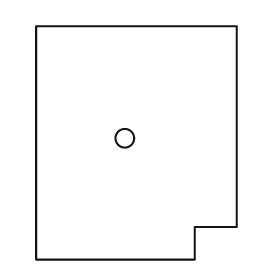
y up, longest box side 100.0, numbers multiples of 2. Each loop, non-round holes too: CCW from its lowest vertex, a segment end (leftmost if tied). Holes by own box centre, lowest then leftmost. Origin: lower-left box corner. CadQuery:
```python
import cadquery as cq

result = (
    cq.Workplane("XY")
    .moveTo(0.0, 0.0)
    .lineTo(68.0, 0.0)
    .lineTo(68.0, 14.0)
    .lineTo(86.0, 14.0)
    .lineTo(86.0, 100.0)
    .lineTo(0.0, 100.0)
    .close()
    .moveTo(38.0, 52.0)
    .circle(4.0)
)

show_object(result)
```